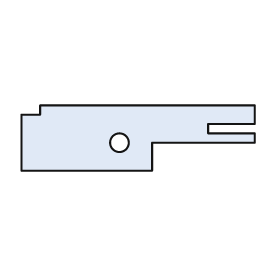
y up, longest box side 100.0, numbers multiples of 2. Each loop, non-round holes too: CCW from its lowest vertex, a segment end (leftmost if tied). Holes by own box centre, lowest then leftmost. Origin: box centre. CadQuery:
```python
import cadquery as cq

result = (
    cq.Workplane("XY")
    .moveTo(-50.0, -14.0)
    .lineTo(6.0, -14.0)
    .lineTo(6.0, -2.0)
    .lineTo(50.0, -2.0)
    .lineTo(50.0, 2.0)
    .lineTo(30.0, 2.0)
    .lineTo(30.0, 6.0)
    .lineTo(50.0, 6.0)
    .lineTo(50.0, 14.0)
    .lineTo(-42.0, 14.0)
    .lineTo(-42.0, 10.0)
    .lineTo(-50.0, 10.0)
    .close()
    .moveTo(-8.0, -2.0)
    .circle(4.0)
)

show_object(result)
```